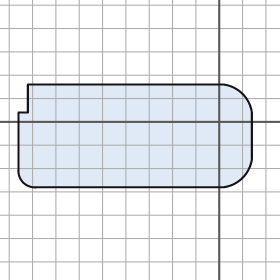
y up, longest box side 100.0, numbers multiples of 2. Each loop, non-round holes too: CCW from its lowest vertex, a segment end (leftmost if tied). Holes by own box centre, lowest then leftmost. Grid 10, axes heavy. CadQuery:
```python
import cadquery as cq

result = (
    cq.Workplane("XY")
    .moveTo(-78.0, -28.0)
    .lineTo(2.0, -28.0)
    .threePointArc((10.0, -24.0), (14.0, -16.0))
    .lineTo(14.0, 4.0)
    .threePointArc((10.0, 12.0), (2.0, 16.0))
    .lineTo(-82.0, 16.0)
    .lineTo(-82.0, 4.0)
    .lineTo(-86.0, 4.0)
    .lineTo(-86.0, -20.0)
    .threePointArc((-84.0, -26.0), (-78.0, -28.0))
    .close()
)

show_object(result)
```